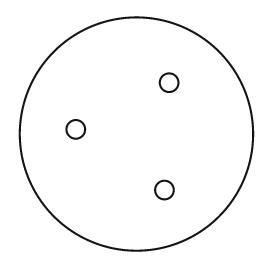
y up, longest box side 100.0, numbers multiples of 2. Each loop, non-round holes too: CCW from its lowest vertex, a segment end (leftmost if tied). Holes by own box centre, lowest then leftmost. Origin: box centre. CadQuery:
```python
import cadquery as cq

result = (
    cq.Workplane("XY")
    .moveTo(0.0, 0.0)
    .circle(50.0)
    .moveTo(12.0, -24.0)
    .circle(4.0)
    .moveTo(-26.0, 2.0)
    .circle(4.0)
    .moveTo(14.0, 22.0)
    .circle(4.0)
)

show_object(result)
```